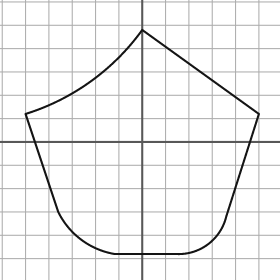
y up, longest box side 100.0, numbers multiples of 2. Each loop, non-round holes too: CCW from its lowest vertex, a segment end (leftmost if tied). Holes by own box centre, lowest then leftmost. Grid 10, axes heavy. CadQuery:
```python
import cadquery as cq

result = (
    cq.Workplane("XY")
    .moveTo(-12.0, -48.0)
    .lineTo(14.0, -48.0)
    .threePointArc((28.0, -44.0), (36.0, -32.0))
    .lineTo(50.0, 12.0)
    .lineTo(0.0, 48.0)
    .threePointArc((-22.0, 26.0), (-50.0, 12.0))
    .lineTo(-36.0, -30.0)
    .threePointArc((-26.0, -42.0), (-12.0, -48.0))
    .close()
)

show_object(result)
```